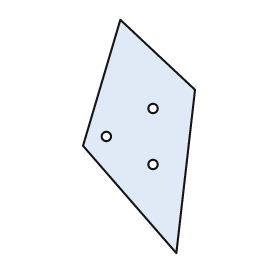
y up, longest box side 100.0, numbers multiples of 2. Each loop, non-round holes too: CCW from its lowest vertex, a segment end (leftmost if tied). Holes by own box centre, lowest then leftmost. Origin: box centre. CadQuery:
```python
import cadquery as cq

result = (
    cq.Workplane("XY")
    .moveTo(16.0, -50.0)
    .lineTo(24.0, 20.0)
    .lineTo(-8.0, 50.0)
    .lineTo(-24.0, -4.0)
    .close()
    .moveTo(6.0, -12.0)
    .circle(2.0)
    .moveTo(-14.0, 0.0)
    .circle(2.0)
    .moveTo(6.0, 12.0)
    .circle(2.0)
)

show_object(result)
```